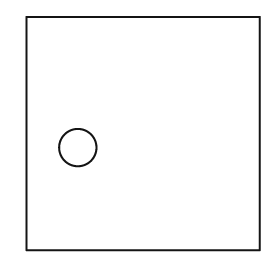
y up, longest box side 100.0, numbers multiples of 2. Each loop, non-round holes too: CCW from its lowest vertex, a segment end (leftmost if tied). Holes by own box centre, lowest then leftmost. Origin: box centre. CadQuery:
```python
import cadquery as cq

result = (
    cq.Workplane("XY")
    .moveTo(-50.0, -50.0)
    .lineTo(50.0, -50.0)
    .lineTo(50.0, 50.0)
    .lineTo(-50.0, 50.0)
    .close()
    .moveTo(-28.0, -6.0)
    .circle(8.0)
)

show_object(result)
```